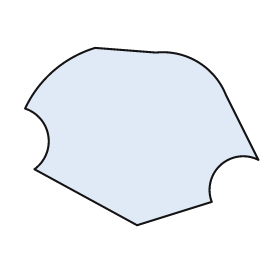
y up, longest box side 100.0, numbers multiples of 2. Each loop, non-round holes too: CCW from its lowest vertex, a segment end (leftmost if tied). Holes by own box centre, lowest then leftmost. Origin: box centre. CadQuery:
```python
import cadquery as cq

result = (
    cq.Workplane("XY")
    .moveTo(-2.0, -38.0)
    .lineTo(30.0, -28.0)
    .threePointArc((34.0, -12.0), (50.0, -10.0))
    .lineTo(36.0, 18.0)
    .threePointArc((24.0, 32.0), (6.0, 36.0))
    .lineTo(-20.0, 38.0)
    .threePointArc((-38.0, 28.0), (-50.0, 12.0))
    .threePointArc((-40.0, 0.0), (-46.0, -14.0))
    .close()
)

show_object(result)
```